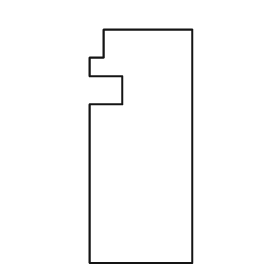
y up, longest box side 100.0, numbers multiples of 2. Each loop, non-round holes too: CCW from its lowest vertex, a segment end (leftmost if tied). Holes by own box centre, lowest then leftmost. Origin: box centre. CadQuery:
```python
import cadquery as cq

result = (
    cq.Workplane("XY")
    .moveTo(-22.0, -50.0)
    .lineTo(22.0, -50.0)
    .lineTo(22.0, 50.0)
    .lineTo(-16.0, 50.0)
    .lineTo(-16.0, 38.0)
    .lineTo(-22.0, 38.0)
    .lineTo(-22.0, 30.0)
    .lineTo(-8.0, 30.0)
    .lineTo(-8.0, 18.0)
    .lineTo(-22.0, 18.0)
    .close()
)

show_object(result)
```